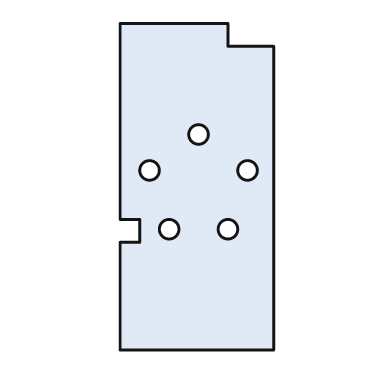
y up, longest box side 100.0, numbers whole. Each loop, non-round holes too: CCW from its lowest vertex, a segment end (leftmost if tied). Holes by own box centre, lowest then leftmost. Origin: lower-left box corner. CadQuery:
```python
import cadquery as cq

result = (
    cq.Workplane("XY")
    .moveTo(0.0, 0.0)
    .lineTo(47.0, 0.0)
    .lineTo(47.0, 93.0)
    .lineTo(33.0, 93.0)
    .lineTo(33.0, 100.0)
    .lineTo(0.0, 100.0)
    .lineTo(0.0, 40.0)
    .lineTo(6.0, 40.0)
    .lineTo(6.0, 33.0)
    .lineTo(0.0, 33.0)
    .close()
    .moveTo(15.0, 37.0)
    .circle(3.0)
    .moveTo(33.0, 37.0)
    .circle(3.0)
    .moveTo(9.0, 55.0)
    .circle(3.0)
    .moveTo(39.0, 55.0)
    .circle(3.0)
    .moveTo(24.0, 66.0)
    .circle(3.0)
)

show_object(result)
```